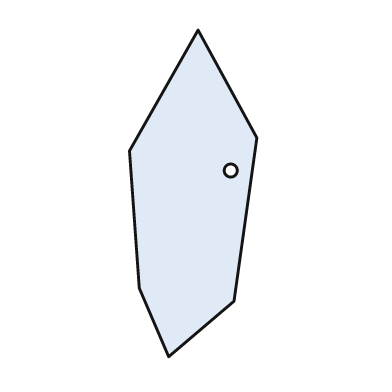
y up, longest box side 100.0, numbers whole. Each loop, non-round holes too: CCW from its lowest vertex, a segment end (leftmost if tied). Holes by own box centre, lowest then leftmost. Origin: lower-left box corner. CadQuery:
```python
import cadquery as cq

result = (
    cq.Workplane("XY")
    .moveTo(12.0, 0.0)
    .lineTo(32.0, 17.0)
    .lineTo(39.0, 67.0)
    .lineTo(21.0, 100.0)
    .lineTo(0.0, 63.0)
    .lineTo(3.0, 21.0)
    .close()
    .moveTo(31.0, 57.0)
    .circle(2.0)
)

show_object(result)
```